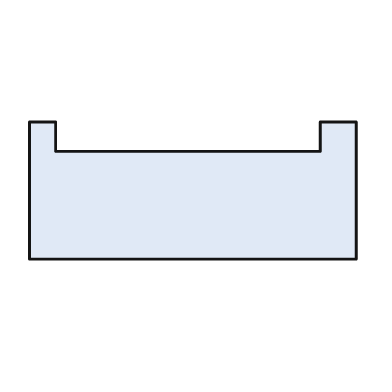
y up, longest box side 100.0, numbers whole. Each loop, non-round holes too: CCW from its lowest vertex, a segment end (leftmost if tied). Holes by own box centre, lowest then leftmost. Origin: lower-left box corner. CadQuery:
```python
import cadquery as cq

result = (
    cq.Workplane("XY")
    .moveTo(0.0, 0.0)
    .lineTo(100.0, 0.0)
    .lineTo(100.0, 42.0)
    .lineTo(89.0, 42.0)
    .lineTo(89.0, 33.0)
    .lineTo(8.0, 33.0)
    .lineTo(8.0, 42.0)
    .lineTo(0.0, 42.0)
    .close()
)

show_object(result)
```